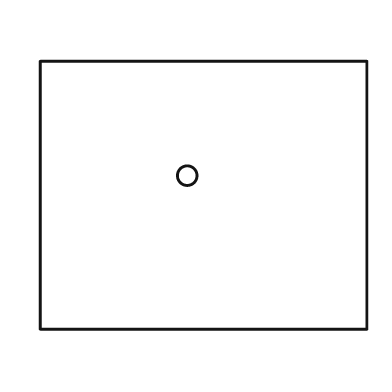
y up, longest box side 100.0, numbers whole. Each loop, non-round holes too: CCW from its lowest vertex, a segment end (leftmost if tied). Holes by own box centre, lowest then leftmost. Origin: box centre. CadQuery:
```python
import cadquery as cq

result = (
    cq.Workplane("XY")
    .moveTo(-50.0, -41.0)
    .lineTo(50.0, -41.0)
    .lineTo(50.0, 41.0)
    .lineTo(-50.0, 41.0)
    .close()
    .moveTo(-5.0, 6.0)
    .circle(3.0)
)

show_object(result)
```